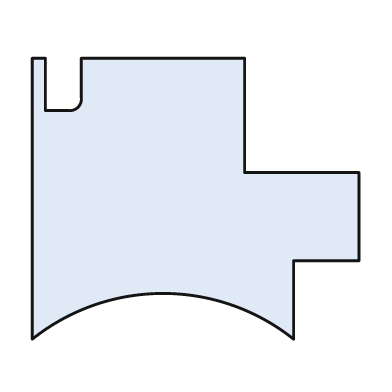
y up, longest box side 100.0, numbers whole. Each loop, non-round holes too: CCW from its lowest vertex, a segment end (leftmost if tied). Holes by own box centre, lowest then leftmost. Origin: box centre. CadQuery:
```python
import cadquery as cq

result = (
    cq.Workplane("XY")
    .moveTo(-50.0, -43.0)
    .threePointArc((-10.0, -29.0), (30.0, -43.0))
    .lineTo(30.0, -19.0)
    .lineTo(50.0, -19.0)
    .lineTo(50.0, 8.0)
    .lineTo(15.0, 8.0)
    .lineTo(15.0, 43.0)
    .lineTo(-35.0, 43.0)
    .lineTo(-35.0, 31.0)
    .threePointArc((-36.0, 28.0), (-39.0, 27.0))
    .lineTo(-46.0, 27.0)
    .lineTo(-46.0, 43.0)
    .lineTo(-50.0, 43.0)
    .close()
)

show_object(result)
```